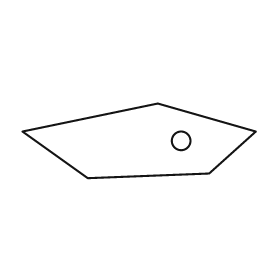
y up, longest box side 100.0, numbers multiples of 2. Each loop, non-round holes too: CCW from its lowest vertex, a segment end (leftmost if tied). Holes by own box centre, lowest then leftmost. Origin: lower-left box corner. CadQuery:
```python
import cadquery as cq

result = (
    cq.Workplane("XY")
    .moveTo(28.0, 0.0)
    .lineTo(80.0, 2.0)
    .lineTo(100.0, 20.0)
    .lineTo(58.0, 32.0)
    .lineTo(0.0, 20.0)
    .close()
    .moveTo(68.0, 16.0)
    .circle(4.0)
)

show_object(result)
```